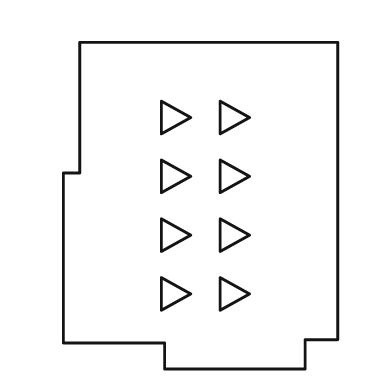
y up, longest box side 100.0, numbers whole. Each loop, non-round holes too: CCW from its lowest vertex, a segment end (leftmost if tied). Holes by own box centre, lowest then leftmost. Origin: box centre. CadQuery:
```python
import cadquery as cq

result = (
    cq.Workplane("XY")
    .moveTo(-11.0, -50.0)
    .lineTo(32.0, -50.0)
    .lineTo(32.0, -41.0)
    .lineTo(42.0, -41.0)
    .lineTo(42.0, 50.0)
    .lineTo(-37.0, 50.0)
    .lineTo(-37.0, 10.0)
    .lineTo(-42.0, 10.0)
    .lineTo(-42.0, -42.0)
    .lineTo(-11.0, -42.0)
    .close()
    .moveTo(-12.0, -32.0)
    .lineTo(-3.0, -27.0)
    .lineTo(-12.0, -22.0)
    .close()
    .moveTo(6.0, -32.0)
    .lineTo(15.0, -27.0)
    .lineTo(6.0, -22.0)
    .close()
    .moveTo(-12.0, -14.0)
    .lineTo(-3.0, -9.0)
    .lineTo(-12.0, -4.0)
    .close()
    .moveTo(6.0, -14.0)
    .lineTo(15.0, -9.0)
    .lineTo(6.0, -4.0)
    .close()
    .moveTo(-12.0, 4.0)
    .lineTo(-3.0, 9.0)
    .lineTo(-12.0, 14.0)
    .close()
    .moveTo(6.0, 4.0)
    .lineTo(15.0, 9.0)
    .lineTo(6.0, 14.0)
    .close()
    .moveTo(-12.0, 22.0)
    .lineTo(-3.0, 27.0)
    .lineTo(-12.0, 32.0)
    .close()
    .moveTo(6.0, 22.0)
    .lineTo(15.0, 27.0)
    .lineTo(6.0, 32.0)
    .close()
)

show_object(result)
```